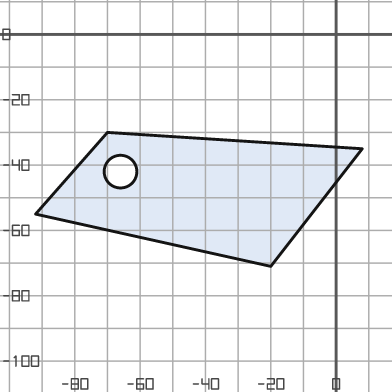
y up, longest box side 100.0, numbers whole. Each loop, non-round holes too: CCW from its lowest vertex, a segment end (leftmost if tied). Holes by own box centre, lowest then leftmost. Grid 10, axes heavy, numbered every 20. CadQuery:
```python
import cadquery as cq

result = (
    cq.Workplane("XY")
    .moveTo(-20.0, -71.0)
    .lineTo(8.0, -35.0)
    .lineTo(-70.0, -30.0)
    .lineTo(-92.0, -55.0)
    .close()
    .moveTo(-66.0, -42.0)
    .circle(5.0)
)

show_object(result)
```